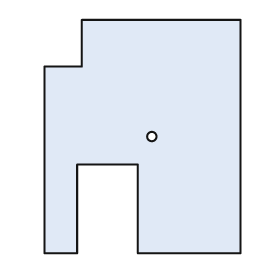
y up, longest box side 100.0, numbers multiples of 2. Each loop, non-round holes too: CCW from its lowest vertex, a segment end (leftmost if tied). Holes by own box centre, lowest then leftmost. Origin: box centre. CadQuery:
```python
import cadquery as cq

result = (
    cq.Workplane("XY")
    .moveTo(-42.0, -50.0)
    .lineTo(-28.0, -50.0)
    .lineTo(-28.0, -12.0)
    .lineTo(-2.0, -12.0)
    .lineTo(-2.0, -50.0)
    .lineTo(42.0, -50.0)
    .lineTo(42.0, 50.0)
    .lineTo(-26.0, 50.0)
    .lineTo(-26.0, 30.0)
    .lineTo(-42.0, 30.0)
    .close()
    .moveTo(4.0, 0.0)
    .circle(2.0)
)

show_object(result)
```